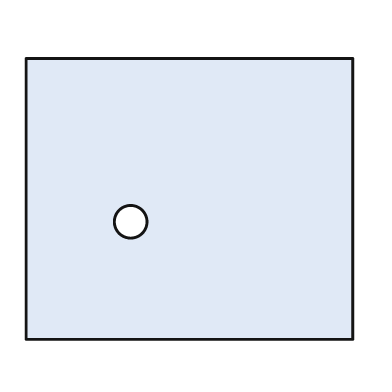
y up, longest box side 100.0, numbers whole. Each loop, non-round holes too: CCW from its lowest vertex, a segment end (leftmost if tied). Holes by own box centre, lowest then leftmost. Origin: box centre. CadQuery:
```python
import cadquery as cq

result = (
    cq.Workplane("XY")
    .moveTo(-50.0, -43.0)
    .lineTo(50.0, -43.0)
    .lineTo(50.0, 43.0)
    .lineTo(-50.0, 43.0)
    .close()
    .moveTo(-18.0, -7.0)
    .circle(5.0)
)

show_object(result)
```